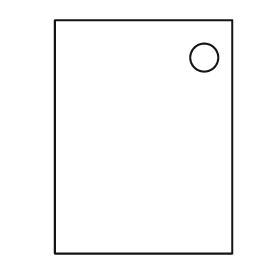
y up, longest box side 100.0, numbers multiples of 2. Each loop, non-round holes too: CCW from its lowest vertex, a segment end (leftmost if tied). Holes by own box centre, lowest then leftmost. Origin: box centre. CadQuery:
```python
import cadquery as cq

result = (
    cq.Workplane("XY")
    .moveTo(-38.0, -50.0)
    .lineTo(38.0, -50.0)
    .lineTo(38.0, 50.0)
    .lineTo(-38.0, 50.0)
    .close()
    .moveTo(26.0, 34.0)
    .circle(6.0)
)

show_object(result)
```